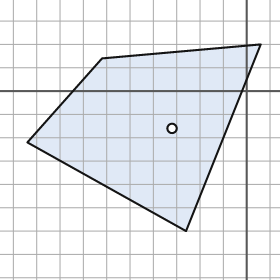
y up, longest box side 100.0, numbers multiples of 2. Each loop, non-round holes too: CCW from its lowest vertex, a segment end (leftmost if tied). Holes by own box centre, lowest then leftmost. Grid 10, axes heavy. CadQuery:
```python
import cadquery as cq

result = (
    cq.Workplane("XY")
    .moveTo(-26.0, -60.0)
    .lineTo(6.0, 20.0)
    .lineTo(-62.0, 14.0)
    .lineTo(-94.0, -22.0)
    .close()
    .moveTo(-32.0, -16.0)
    .circle(2.0)
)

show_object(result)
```